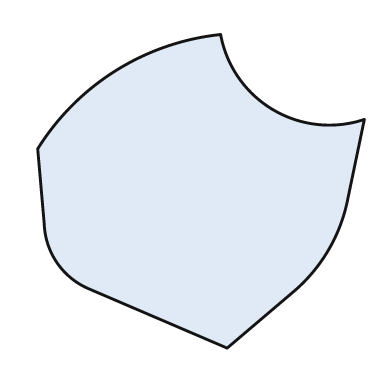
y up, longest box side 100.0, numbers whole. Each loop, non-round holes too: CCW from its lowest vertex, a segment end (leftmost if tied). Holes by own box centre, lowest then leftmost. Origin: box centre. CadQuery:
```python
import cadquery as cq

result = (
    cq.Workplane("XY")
    .moveTo(8.0, -48.0)
    .lineTo(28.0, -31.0)
    .threePointArc((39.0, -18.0), (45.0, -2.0))
    .lineTo(50.0, 22.0)
    .threePointArc((22.0, 25.0), (6.0, 48.0))
    .threePointArc((-26.0, 37.0), (-50.0, 13.0))
    .lineTo(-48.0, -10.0)
    .threePointArc((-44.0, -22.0), (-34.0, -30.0))
    .close()
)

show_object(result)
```